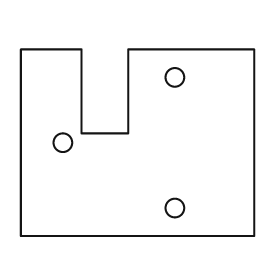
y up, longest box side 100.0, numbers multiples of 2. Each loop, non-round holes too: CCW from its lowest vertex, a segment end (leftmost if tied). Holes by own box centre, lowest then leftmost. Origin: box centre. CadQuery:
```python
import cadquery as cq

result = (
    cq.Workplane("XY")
    .moveTo(-50.0, -40.0)
    .lineTo(50.0, -40.0)
    .lineTo(50.0, 40.0)
    .lineTo(-4.0, 40.0)
    .lineTo(-4.0, 4.0)
    .lineTo(-24.0, 4.0)
    .lineTo(-24.0, 40.0)
    .lineTo(-50.0, 40.0)
    .close()
    .moveTo(16.0, -28.0)
    .circle(4.0)
    .moveTo(-32.0, 0.0)
    .circle(4.0)
    .moveTo(16.0, 28.0)
    .circle(4.0)
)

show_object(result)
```